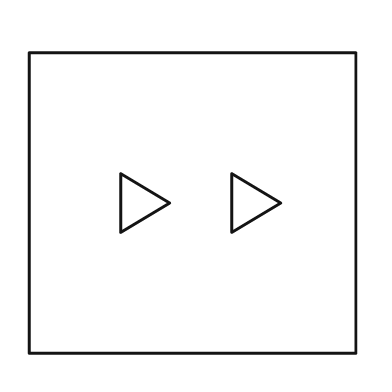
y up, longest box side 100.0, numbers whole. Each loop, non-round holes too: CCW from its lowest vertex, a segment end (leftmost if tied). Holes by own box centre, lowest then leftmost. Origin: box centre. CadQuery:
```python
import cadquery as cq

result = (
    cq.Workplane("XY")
    .moveTo(-50.0, -46.0)
    .lineTo(50.0, -46.0)
    .lineTo(50.0, 46.0)
    .lineTo(-50.0, 46.0)
    .close()
    .moveTo(-22.0, -9.0)
    .lineTo(-7.0, 0.0)
    .lineTo(-22.0, 9.0)
    .close()
    .moveTo(12.0, -9.0)
    .lineTo(27.0, 0.0)
    .lineTo(12.0, 9.0)
    .close()
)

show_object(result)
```